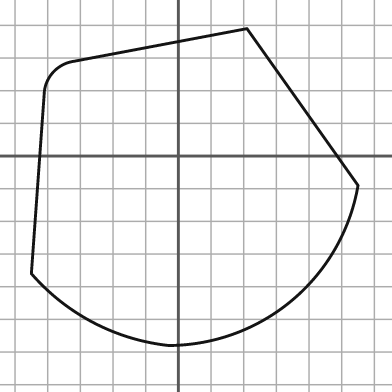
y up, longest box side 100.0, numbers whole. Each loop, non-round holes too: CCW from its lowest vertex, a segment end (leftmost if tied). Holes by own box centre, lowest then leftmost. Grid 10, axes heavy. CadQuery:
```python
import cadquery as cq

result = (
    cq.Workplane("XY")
    .moveTo(-3.0, -58.0)
    .threePointArc((35.0, -44.0), (55.0, -9.0))
    .lineTo(21.0, 39.0)
    .lineTo(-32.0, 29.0)
    .threePointArc((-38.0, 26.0), (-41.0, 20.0))
    .lineTo(-45.0, -36.0)
    .threePointArc((-26.0, -51.0), (-3.0, -58.0))
    .close()
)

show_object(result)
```